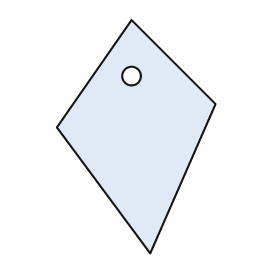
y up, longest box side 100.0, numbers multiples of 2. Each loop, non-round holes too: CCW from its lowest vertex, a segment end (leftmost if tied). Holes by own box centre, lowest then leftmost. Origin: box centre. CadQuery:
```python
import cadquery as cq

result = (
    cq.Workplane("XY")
    .moveTo(6.0, -50.0)
    .lineTo(34.0, 14.0)
    .lineTo(-2.0, 50.0)
    .lineTo(-34.0, 4.0)
    .close()
    .moveTo(-2.0, 26.0)
    .circle(4.0)
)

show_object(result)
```